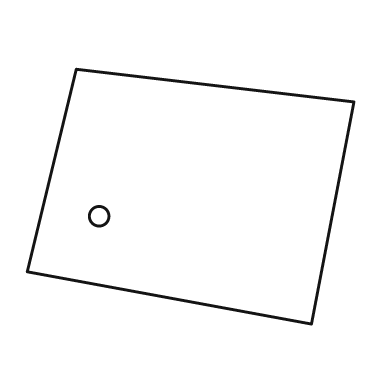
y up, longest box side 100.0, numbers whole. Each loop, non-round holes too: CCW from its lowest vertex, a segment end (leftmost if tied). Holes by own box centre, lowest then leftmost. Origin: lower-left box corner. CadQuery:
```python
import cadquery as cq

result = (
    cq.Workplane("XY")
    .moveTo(87.0, 0.0)
    .lineTo(100.0, 68.0)
    .lineTo(15.0, 78.0)
    .lineTo(0.0, 16.0)
    .close()
    .moveTo(22.0, 33.0)
    .circle(3.0)
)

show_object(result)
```